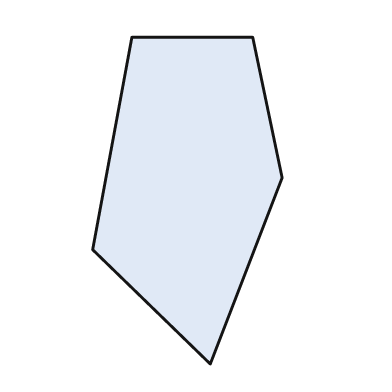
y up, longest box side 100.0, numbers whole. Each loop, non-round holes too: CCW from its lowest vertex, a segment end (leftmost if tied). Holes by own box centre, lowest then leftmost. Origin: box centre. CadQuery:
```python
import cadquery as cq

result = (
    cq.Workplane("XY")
    .moveTo(7.0, -50.0)
    .lineTo(29.0, 7.0)
    .lineTo(20.0, 50.0)
    .lineTo(-17.0, 50.0)
    .lineTo(-29.0, -15.0)
    .close()
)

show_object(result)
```